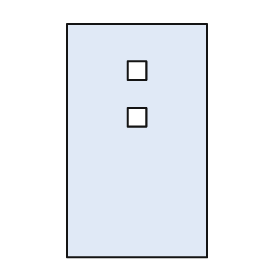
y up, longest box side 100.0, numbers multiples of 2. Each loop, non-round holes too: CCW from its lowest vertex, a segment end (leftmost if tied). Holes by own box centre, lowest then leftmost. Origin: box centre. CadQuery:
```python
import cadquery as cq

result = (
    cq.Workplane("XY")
    .moveTo(-30.0, -50.0)
    .lineTo(30.0, -50.0)
    .lineTo(30.0, 50.0)
    .lineTo(-30.0, 50.0)
    .close()
    .moveTo(-4.0, 6.0)
    .lineTo(4.0, 6.0)
    .lineTo(4.0, 14.0)
    .lineTo(-4.0, 14.0)
    .close()
    .moveTo(-4.0, 26.0)
    .lineTo(4.0, 26.0)
    .lineTo(4.0, 34.0)
    .lineTo(-4.0, 34.0)
    .close()
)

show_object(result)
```